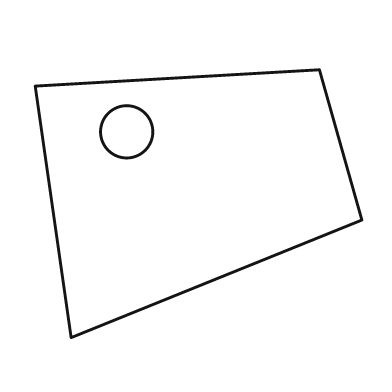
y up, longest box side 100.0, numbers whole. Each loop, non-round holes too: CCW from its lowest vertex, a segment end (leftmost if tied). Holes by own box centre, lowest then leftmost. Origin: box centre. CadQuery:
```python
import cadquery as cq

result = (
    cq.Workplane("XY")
    .moveTo(-39.0, -41.0)
    .lineTo(50.0, -5.0)
    .lineTo(37.0, 41.0)
    .lineTo(-50.0, 36.0)
    .close()
    .moveTo(-22.0, 22.0)
    .circle(8.0)
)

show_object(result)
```